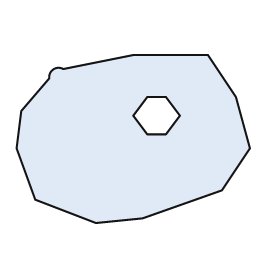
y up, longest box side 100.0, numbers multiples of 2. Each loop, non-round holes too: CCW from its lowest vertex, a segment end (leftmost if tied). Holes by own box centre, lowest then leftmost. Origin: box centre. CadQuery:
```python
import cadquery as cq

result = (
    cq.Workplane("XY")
    .moveTo(-16.0, -36.0)
    .lineTo(4.0, -34.0)
    .lineTo(38.0, -22.0)
    .lineTo(50.0, -4.0)
    .lineTo(44.0, 18.0)
    .lineTo(32.0, 36.0)
    .lineTo(0.0, 36.0)
    .lineTo(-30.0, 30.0)
    .threePointArc((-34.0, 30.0), (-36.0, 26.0))
    .lineTo(-48.0, 12.0)
    .lineTo(-50.0, -4.0)
    .lineTo(-42.0, -26.0)
    .close()
    .moveTo(6.0, 2.0)
    .lineTo(14.0, 2.0)
    .lineTo(20.0, 10.0)
    .lineTo(14.0, 18.0)
    .lineTo(6.0, 18.0)
    .lineTo(0.0, 10.0)
    .close()
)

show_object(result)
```